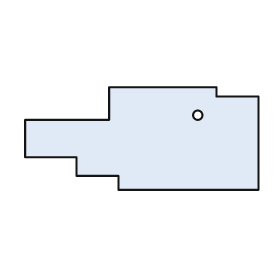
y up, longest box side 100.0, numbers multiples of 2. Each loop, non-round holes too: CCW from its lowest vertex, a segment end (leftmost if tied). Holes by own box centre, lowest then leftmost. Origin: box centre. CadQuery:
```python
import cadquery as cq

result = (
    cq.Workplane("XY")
    .moveTo(-10.0, -22.0)
    .lineTo(50.0, -22.0)
    .lineTo(50.0, 18.0)
    .lineTo(32.0, 18.0)
    .lineTo(32.0, 22.0)
    .lineTo(-14.0, 22.0)
    .lineTo(-14.0, 8.0)
    .lineTo(-50.0, 8.0)
    .lineTo(-50.0, -8.0)
    .lineTo(-28.0, -8.0)
    .lineTo(-28.0, -16.0)
    .lineTo(-10.0, -16.0)
    .close()
    .moveTo(24.0, 10.0)
    .circle(2.0)
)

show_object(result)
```